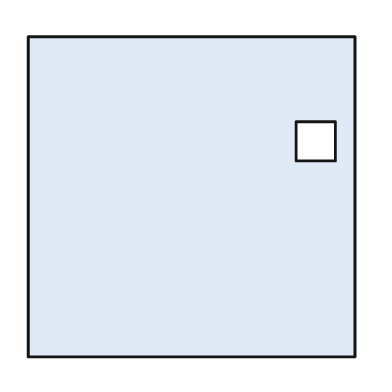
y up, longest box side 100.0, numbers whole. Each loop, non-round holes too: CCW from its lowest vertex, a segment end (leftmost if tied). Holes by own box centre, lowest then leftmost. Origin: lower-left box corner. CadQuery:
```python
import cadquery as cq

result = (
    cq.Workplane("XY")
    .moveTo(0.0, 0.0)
    .lineTo(100.0, 0.0)
    .lineTo(100.0, 98.0)
    .lineTo(0.0, 98.0)
    .close()
    .moveTo(82.0, 60.0)
    .lineTo(94.0, 60.0)
    .lineTo(94.0, 72.0)
    .lineTo(82.0, 72.0)
    .close()
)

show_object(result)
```